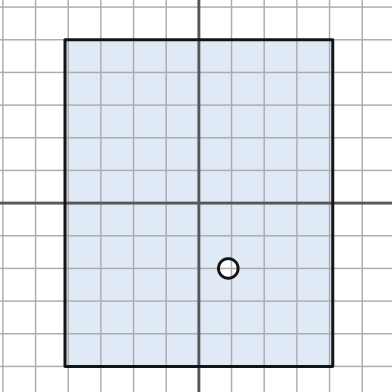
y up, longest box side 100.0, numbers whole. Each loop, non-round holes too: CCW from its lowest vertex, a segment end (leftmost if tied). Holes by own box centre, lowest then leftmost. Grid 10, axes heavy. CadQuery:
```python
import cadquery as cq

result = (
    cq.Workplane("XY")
    .moveTo(-41.0, -50.0)
    .lineTo(41.0, -50.0)
    .lineTo(41.0, 50.0)
    .lineTo(-41.0, 50.0)
    .close()
    .moveTo(9.0, -20.0)
    .circle(3.0)
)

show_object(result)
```